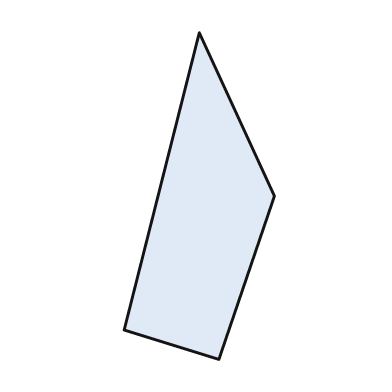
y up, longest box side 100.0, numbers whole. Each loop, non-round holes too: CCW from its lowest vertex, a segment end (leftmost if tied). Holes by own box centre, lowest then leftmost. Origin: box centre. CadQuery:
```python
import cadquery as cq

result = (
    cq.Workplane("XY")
    .moveTo(6.0, -50.0)
    .lineTo(23.0, 0.0)
    .lineTo(0.0, 50.0)
    .lineTo(-23.0, -41.0)
    .close()
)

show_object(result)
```